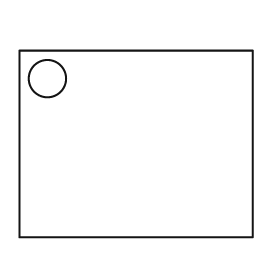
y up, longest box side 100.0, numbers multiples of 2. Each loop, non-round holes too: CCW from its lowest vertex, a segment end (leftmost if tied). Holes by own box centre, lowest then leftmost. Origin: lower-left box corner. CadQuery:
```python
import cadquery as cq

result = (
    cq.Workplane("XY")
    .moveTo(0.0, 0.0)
    .lineTo(100.0, 0.0)
    .lineTo(100.0, 80.0)
    .lineTo(0.0, 80.0)
    .close()
    .moveTo(12.0, 68.0)
    .circle(8.0)
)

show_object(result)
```